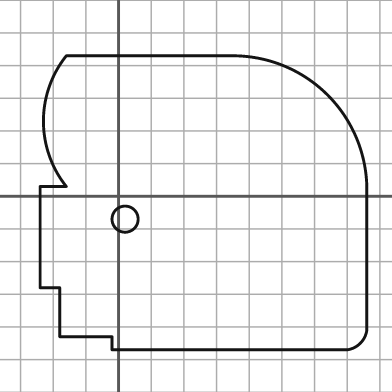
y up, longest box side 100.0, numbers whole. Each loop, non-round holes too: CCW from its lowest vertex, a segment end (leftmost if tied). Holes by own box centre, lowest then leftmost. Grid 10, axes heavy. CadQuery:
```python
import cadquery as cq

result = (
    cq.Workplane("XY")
    .moveTo(-2.0, -47.0)
    .lineTo(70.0, -47.0)
    .threePointArc((74.0, -45.0), (76.0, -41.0))
    .lineTo(76.0, 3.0)
    .threePointArc((64.0, 31.0), (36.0, 43.0))
    .lineTo(-16.0, 43.0)
    .threePointArc((-23.0, 23.0), (-16.0, 3.0))
    .lineTo(-24.0, 3.0)
    .lineTo(-24.0, -28.0)
    .lineTo(-18.0, -28.0)
    .lineTo(-18.0, -43.0)
    .lineTo(-2.0, -43.0)
    .close()
    .moveTo(2.0, -7.0)
    .circle(4.0)
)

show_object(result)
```